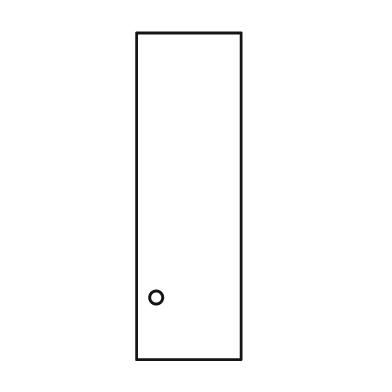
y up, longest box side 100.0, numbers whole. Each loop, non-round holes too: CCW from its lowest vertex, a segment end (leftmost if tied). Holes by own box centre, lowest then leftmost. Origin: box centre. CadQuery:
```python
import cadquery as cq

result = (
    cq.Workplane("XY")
    .moveTo(-16.0, -50.0)
    .lineTo(16.0, -50.0)
    .lineTo(16.0, 50.0)
    .lineTo(-16.0, 50.0)
    .close()
    .moveTo(-10.0, -31.0)
    .circle(2.0)
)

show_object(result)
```